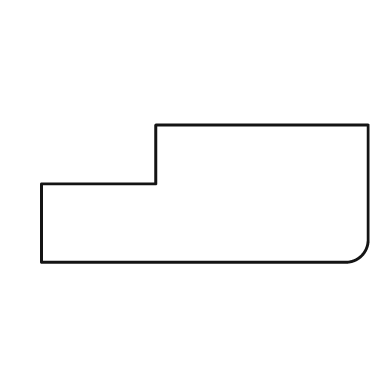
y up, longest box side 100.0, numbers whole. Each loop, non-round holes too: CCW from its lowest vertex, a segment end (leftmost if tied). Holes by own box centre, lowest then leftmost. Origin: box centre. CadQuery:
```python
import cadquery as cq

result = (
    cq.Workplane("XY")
    .moveTo(-50.0, -21.0)
    .lineTo(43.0, -21.0)
    .threePointArc((48.0, -19.0), (50.0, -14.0))
    .lineTo(50.0, 21.0)
    .lineTo(-15.0, 21.0)
    .lineTo(-15.0, 3.0)
    .lineTo(-50.0, 3.0)
    .close()
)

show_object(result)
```